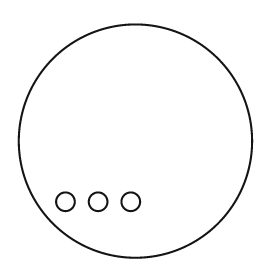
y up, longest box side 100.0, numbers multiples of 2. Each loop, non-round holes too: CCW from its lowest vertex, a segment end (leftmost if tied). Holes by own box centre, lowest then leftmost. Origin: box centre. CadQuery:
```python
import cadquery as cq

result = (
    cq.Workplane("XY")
    .moveTo(0.0, 0.0)
    .circle(50.0)
    .moveTo(-30.0, -26.0)
    .circle(4.0)
    .moveTo(-16.0, -26.0)
    .circle(4.0)
    .moveTo(-2.0, -26.0)
    .circle(4.0)
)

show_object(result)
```